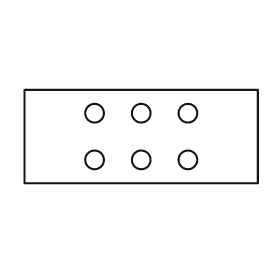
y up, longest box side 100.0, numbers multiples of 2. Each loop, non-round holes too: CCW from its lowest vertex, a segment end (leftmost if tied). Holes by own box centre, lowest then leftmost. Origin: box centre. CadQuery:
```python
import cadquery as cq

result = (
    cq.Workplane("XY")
    .moveTo(-50.0, -20.0)
    .lineTo(50.0, -20.0)
    .lineTo(50.0, 20.0)
    .lineTo(-50.0, 20.0)
    .close()
    .moveTo(-20.0, -10.0)
    .circle(4.0)
    .moveTo(0.0, -10.0)
    .circle(4.0)
    .moveTo(20.0, -10.0)
    .circle(4.0)
    .moveTo(-20.0, 10.0)
    .circle(4.0)
    .moveTo(0.0, 10.0)
    .circle(4.0)
    .moveTo(20.0, 10.0)
    .circle(4.0)
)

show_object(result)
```